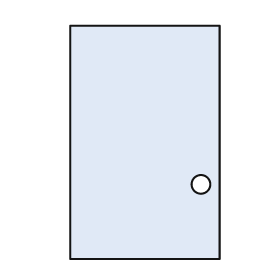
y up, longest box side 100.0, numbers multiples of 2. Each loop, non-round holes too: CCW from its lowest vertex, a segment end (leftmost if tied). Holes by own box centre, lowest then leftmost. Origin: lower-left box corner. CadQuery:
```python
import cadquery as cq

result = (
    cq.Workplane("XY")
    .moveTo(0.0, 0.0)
    .lineTo(64.0, 0.0)
    .lineTo(64.0, 100.0)
    .lineTo(0.0, 100.0)
    .close()
    .moveTo(56.0, 32.0)
    .circle(4.0)
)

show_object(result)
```